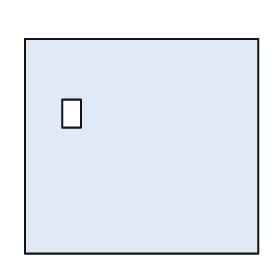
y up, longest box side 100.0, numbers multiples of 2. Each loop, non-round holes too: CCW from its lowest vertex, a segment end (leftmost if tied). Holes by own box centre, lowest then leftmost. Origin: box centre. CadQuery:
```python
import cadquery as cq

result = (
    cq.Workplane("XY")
    .moveTo(-50.0, -46.0)
    .lineTo(50.0, -46.0)
    .lineTo(50.0, 46.0)
    .lineTo(-50.0, 46.0)
    .close()
    .moveTo(-34.0, 8.0)
    .lineTo(-26.0, 8.0)
    .lineTo(-26.0, 20.0)
    .lineTo(-34.0, 20.0)
    .close()
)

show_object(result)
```